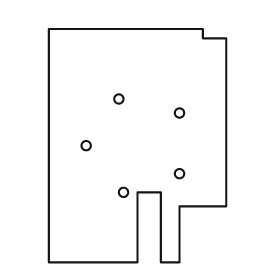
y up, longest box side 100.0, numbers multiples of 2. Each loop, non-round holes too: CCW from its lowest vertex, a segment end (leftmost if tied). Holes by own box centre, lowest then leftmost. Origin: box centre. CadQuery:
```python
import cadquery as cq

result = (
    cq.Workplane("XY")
    .moveTo(-38.0, -50.0)
    .lineTo(0.0, -50.0)
    .lineTo(0.0, -20.0)
    .lineTo(10.0, -20.0)
    .lineTo(10.0, -50.0)
    .lineTo(18.0, -50.0)
    .lineTo(18.0, -26.0)
    .lineTo(38.0, -26.0)
    .lineTo(38.0, 46.0)
    .lineTo(28.0, 46.0)
    .lineTo(28.0, 50.0)
    .lineTo(-38.0, 50.0)
    .close()
    .moveTo(-6.0, -20.0)
    .circle(2.0)
    .moveTo(18.0, -12.0)
    .circle(2.0)
    .moveTo(-22.0, 0.0)
    .circle(2.0)
    .moveTo(18.0, 14.0)
    .circle(2.0)
    .moveTo(-8.0, 20.0)
    .circle(2.0)
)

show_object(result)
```